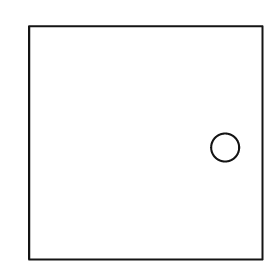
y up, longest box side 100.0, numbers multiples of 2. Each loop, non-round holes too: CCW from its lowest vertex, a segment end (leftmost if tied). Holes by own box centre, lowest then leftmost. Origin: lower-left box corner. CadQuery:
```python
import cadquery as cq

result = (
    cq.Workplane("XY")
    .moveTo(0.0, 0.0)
    .lineTo(100.0, 0.0)
    .lineTo(100.0, 100.0)
    .lineTo(0.0, 100.0)
    .close()
    .moveTo(84.0, 48.0)
    .circle(6.0)
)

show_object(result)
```